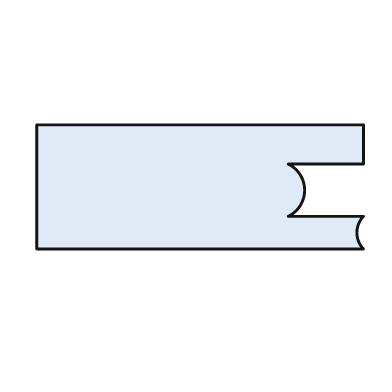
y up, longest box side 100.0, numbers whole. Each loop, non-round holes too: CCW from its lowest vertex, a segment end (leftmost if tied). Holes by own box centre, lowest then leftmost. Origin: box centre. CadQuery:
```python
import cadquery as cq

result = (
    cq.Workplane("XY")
    .moveTo(-50.0, -19.0)
    .lineTo(50.0, -19.0)
    .threePointArc((48.0, -14.0), (50.0, -9.0))
    .lineTo(27.0, -9.0)
    .threePointArc((32.0, -1.0), (27.0, 7.0))
    .lineTo(50.0, 7.0)
    .lineTo(50.0, 19.0)
    .lineTo(-50.0, 19.0)
    .close()
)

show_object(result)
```